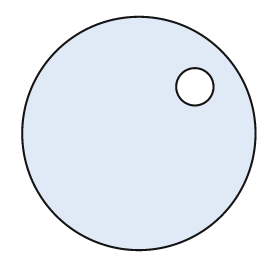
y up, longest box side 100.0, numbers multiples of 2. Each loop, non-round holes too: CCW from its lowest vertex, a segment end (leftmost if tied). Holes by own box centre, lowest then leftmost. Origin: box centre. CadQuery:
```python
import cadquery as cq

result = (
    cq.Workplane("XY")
    .moveTo(0.0, 0.0)
    .circle(50.0)
    .moveTo(24.0, 20.0)
    .circle(8.0)
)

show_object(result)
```